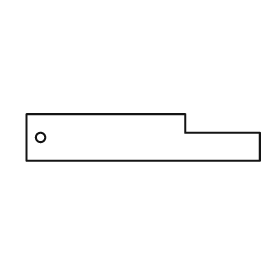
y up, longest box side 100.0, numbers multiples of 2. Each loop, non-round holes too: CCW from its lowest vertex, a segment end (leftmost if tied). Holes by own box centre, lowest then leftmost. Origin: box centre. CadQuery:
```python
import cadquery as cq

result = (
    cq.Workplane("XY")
    .moveTo(-50.0, -10.0)
    .lineTo(50.0, -10.0)
    .lineTo(50.0, 2.0)
    .lineTo(18.0, 2.0)
    .lineTo(18.0, 10.0)
    .lineTo(-50.0, 10.0)
    .close()
    .moveTo(-44.0, 0.0)
    .circle(2.0)
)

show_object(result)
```